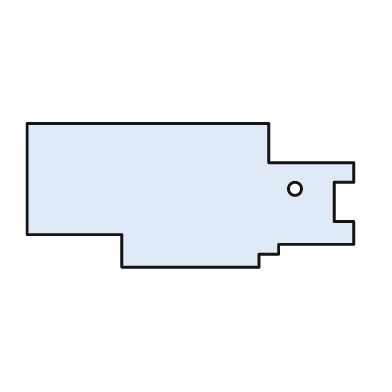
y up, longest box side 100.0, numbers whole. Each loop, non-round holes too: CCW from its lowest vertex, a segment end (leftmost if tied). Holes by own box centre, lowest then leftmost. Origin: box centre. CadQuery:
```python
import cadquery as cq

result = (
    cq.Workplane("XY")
    .moveTo(-21.0, -22.0)
    .lineTo(21.0, -22.0)
    .lineTo(21.0, -18.0)
    .lineTo(27.0, -18.0)
    .lineTo(27.0, -15.0)
    .lineTo(50.0, -15.0)
    .lineTo(50.0, -8.0)
    .lineTo(44.0, -8.0)
    .lineTo(44.0, 4.0)
    .lineTo(50.0, 4.0)
    .lineTo(50.0, 10.0)
    .lineTo(24.0, 10.0)
    .lineTo(24.0, 22.0)
    .lineTo(-50.0, 22.0)
    .lineTo(-50.0, -12.0)
    .lineTo(-21.0, -12.0)
    .close()
    .moveTo(32.0, 2.0)
    .circle(2.0)
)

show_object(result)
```